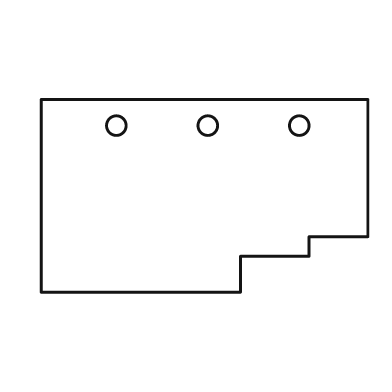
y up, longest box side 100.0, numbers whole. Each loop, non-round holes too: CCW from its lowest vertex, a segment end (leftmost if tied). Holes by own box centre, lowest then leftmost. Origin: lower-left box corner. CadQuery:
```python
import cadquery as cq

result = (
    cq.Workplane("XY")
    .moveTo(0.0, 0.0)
    .lineTo(61.0, 0.0)
    .lineTo(61.0, 11.0)
    .lineTo(82.0, 11.0)
    .lineTo(82.0, 17.0)
    .lineTo(100.0, 17.0)
    .lineTo(100.0, 59.0)
    .lineTo(0.0, 59.0)
    .close()
    .moveTo(23.0, 51.0)
    .circle(3.0)
    .moveTo(51.0, 51.0)
    .circle(3.0)
    .moveTo(79.0, 51.0)
    .circle(3.0)
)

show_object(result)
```